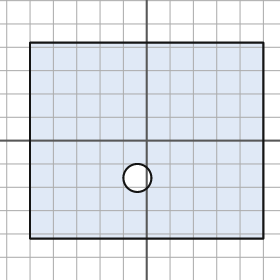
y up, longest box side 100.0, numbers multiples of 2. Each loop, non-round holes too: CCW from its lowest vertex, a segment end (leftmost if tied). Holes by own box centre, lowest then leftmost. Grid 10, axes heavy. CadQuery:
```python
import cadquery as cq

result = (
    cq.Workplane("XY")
    .moveTo(-50.0, -42.0)
    .lineTo(50.0, -42.0)
    .lineTo(50.0, 42.0)
    .lineTo(-50.0, 42.0)
    .close()
    .moveTo(-4.0, -16.0)
    .circle(6.0)
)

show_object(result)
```